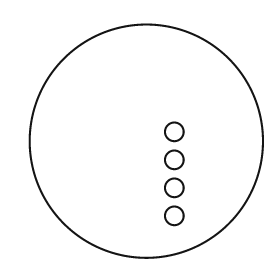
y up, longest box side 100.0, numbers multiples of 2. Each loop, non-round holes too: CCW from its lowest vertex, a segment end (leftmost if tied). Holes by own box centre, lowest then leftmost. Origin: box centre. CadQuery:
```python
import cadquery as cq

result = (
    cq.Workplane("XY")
    .moveTo(0.0, 0.0)
    .circle(50.0)
    .moveTo(12.0, -32.0)
    .circle(4.0)
    .moveTo(12.0, -20.0)
    .circle(4.0)
    .moveTo(12.0, -8.0)
    .circle(4.0)
    .moveTo(12.0, 4.0)
    .circle(4.0)
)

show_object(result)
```